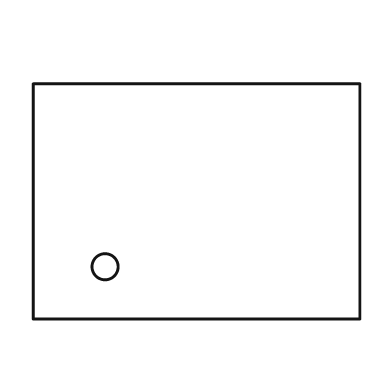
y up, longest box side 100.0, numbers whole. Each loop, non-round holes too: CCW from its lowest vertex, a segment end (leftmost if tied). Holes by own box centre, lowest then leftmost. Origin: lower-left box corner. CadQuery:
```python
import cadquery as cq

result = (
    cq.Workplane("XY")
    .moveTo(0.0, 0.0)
    .lineTo(100.0, 0.0)
    .lineTo(100.0, 72.0)
    .lineTo(0.0, 72.0)
    .close()
    .moveTo(22.0, 16.0)
    .circle(4.0)
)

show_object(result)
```